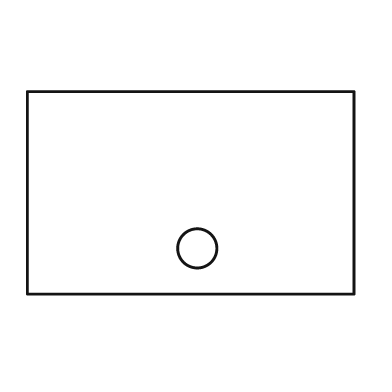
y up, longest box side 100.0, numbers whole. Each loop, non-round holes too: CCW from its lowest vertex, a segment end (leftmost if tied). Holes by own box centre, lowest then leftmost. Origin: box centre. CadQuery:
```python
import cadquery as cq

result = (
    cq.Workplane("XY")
    .moveTo(-50.0, -31.0)
    .lineTo(50.0, -31.0)
    .lineTo(50.0, 31.0)
    .lineTo(-50.0, 31.0)
    .close()
    .moveTo(2.0, -17.0)
    .circle(6.0)
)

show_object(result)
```